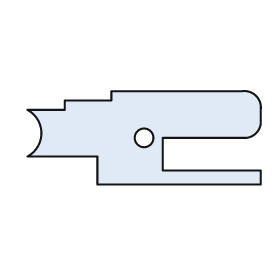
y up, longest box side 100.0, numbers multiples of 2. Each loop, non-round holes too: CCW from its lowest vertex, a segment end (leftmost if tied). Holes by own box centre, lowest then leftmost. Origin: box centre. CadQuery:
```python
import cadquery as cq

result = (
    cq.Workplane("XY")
    .moveTo(-20.0, -20.0)
    .lineTo(50.0, -20.0)
    .lineTo(50.0, -14.0)
    .lineTo(8.0, -14.0)
    .lineTo(8.0, 0.0)
    .lineTo(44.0, 0.0)
    .threePointArc((48.0, 2.0), (50.0, 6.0))
    .lineTo(50.0, 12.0)
    .threePointArc((48.0, 18.0), (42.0, 20.0))
    .lineTo(-14.0, 20.0)
    .lineTo(-14.0, 16.0)
    .lineTo(-34.0, 16.0)
    .lineTo(-34.0, 12.0)
    .lineTo(-50.0, 12.0)
    .threePointArc((-44.0, 2.0), (-50.0, -8.0))
    .lineTo(-20.0, -8.0)
    .close()
    .moveTo(0.0, 0.0)
    .circle(4.0)
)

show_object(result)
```